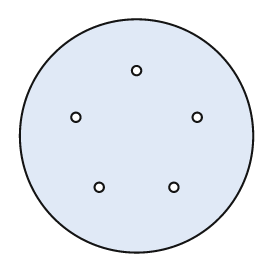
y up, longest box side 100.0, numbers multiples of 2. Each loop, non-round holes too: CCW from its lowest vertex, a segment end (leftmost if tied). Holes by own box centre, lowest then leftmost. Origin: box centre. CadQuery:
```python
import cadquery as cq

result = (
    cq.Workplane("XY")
    .moveTo(0.0, 0.0)
    .circle(50.0)
    .moveTo(-16.0, -22.0)
    .circle(2.0)
    .moveTo(16.0, -22.0)
    .circle(2.0)
    .moveTo(-26.0, 8.0)
    .circle(2.0)
    .moveTo(26.0, 8.0)
    .circle(2.0)
    .moveTo(0.0, 28.0)
    .circle(2.0)
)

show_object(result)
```